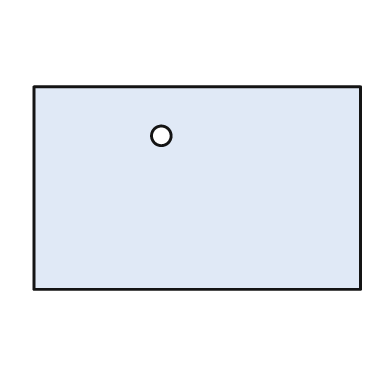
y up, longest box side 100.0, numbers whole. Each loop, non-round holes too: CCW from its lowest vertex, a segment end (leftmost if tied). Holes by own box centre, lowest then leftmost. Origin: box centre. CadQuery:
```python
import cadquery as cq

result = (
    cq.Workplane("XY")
    .moveTo(-50.0, -31.0)
    .lineTo(50.0, -31.0)
    .lineTo(50.0, 31.0)
    .lineTo(-50.0, 31.0)
    .close()
    .moveTo(-11.0, 16.0)
    .circle(3.0)
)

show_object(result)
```